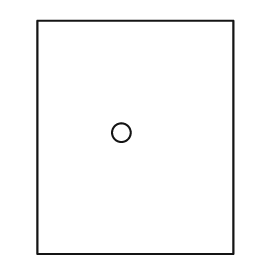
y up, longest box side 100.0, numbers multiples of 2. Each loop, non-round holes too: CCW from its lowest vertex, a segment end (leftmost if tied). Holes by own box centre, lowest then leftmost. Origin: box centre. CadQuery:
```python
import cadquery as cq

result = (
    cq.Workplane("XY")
    .moveTo(-42.0, -50.0)
    .lineTo(42.0, -50.0)
    .lineTo(42.0, 50.0)
    .lineTo(-42.0, 50.0)
    .close()
    .moveTo(-6.0, 2.0)
    .circle(4.0)
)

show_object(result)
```